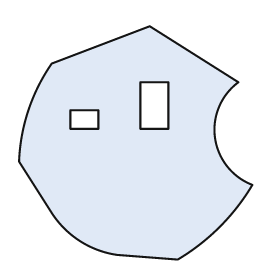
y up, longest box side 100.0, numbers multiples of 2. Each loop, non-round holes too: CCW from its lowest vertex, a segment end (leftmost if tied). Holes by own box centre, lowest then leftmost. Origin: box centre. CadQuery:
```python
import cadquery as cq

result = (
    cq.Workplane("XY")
    .moveTo(18.0, -50.0)
    .threePointArc((36.0, -36.0), (50.0, -18.0))
    .threePointArc((34.0, 2.0), (44.0, 26.0))
    .lineTo(6.0, 50.0)
    .lineTo(-36.0, 34.0)
    .threePointArc((-46.0, 14.0), (-50.0, -8.0))
    .lineTo(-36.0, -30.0)
    .threePointArc((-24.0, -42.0), (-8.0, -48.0))
    .close()
    .moveTo(-28.0, 6.0)
    .lineTo(-16.0, 6.0)
    .lineTo(-16.0, 14.0)
    .lineTo(-28.0, 14.0)
    .close()
    .moveTo(2.0, 6.0)
    .lineTo(14.0, 6.0)
    .lineTo(14.0, 26.0)
    .lineTo(2.0, 26.0)
    .close()
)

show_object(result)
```